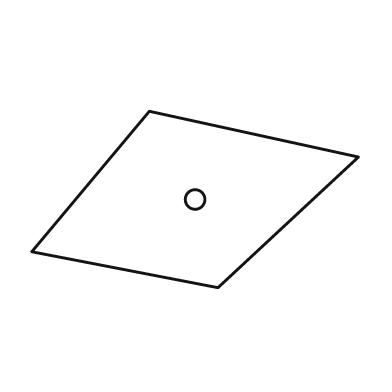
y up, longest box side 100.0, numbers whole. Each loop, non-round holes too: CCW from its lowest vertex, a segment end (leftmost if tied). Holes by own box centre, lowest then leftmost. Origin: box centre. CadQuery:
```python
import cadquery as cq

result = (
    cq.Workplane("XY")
    .moveTo(7.0, -27.0)
    .lineTo(50.0, 13.0)
    .lineTo(-14.0, 27.0)
    .lineTo(-50.0, -16.0)
    .close()
    .moveTo(0.0, 0.0)
    .circle(3.0)
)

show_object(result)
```